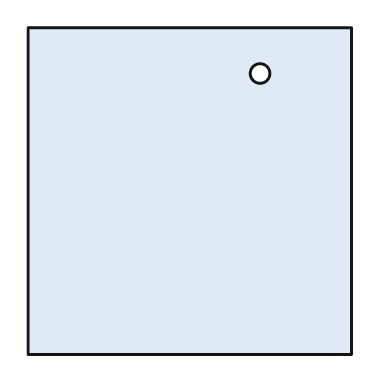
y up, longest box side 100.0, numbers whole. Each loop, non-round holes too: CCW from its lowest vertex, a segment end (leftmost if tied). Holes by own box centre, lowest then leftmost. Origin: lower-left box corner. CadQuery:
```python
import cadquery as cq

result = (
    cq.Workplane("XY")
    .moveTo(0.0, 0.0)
    .lineTo(99.0, 0.0)
    .lineTo(99.0, 100.0)
    .lineTo(0.0, 100.0)
    .close()
    .moveTo(71.0, 86.0)
    .circle(3.0)
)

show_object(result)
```